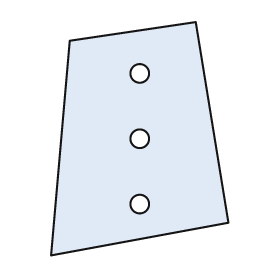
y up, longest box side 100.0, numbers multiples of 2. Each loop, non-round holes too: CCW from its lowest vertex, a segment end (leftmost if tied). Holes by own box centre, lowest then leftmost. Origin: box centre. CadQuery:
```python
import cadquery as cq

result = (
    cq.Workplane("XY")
    .moveTo(-38.0, -50.0)
    .lineTo(38.0, -36.0)
    .lineTo(24.0, 50.0)
    .lineTo(-30.0, 42.0)
    .close()
    .moveTo(0.0, -28.0)
    .circle(4.0)
    .moveTo(0.0, 0.0)
    .circle(4.0)
    .moveTo(0.0, 28.0)
    .circle(4.0)
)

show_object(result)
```